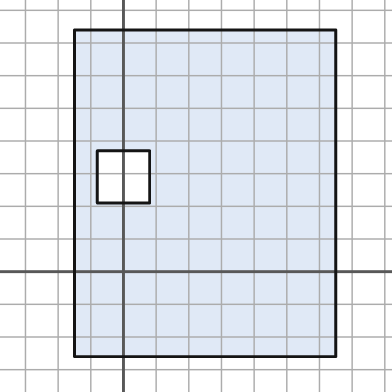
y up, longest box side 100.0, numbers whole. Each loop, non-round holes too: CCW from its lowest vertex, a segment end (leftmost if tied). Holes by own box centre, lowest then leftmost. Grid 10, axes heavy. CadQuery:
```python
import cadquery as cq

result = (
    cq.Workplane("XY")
    .moveTo(-15.0, -26.0)
    .lineTo(65.0, -26.0)
    .lineTo(65.0, 74.0)
    .lineTo(-15.0, 74.0)
    .close()
    .moveTo(-8.0, 21.0)
    .lineTo(8.0, 21.0)
    .lineTo(8.0, 37.0)
    .lineTo(-8.0, 37.0)
    .close()
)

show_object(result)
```